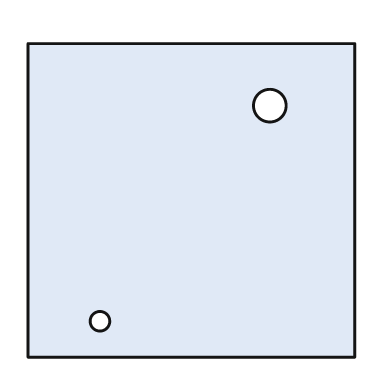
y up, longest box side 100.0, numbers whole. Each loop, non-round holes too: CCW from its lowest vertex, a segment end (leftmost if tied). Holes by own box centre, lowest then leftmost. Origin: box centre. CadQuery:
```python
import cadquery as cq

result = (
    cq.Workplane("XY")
    .moveTo(-50.0, -48.0)
    .lineTo(50.0, -48.0)
    .lineTo(50.0, 48.0)
    .lineTo(-50.0, 48.0)
    .close()
    .moveTo(-28.0, -37.0)
    .circle(3.0)
    .moveTo(24.0, 29.0)
    .circle(5.0)
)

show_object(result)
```